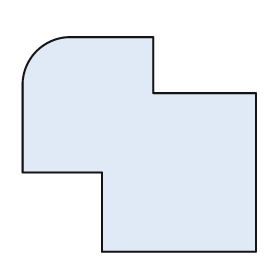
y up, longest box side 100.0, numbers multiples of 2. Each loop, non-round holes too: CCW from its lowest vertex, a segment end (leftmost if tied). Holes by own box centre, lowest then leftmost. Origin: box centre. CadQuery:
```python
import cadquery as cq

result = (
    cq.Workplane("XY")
    .moveTo(-16.0, -46.0)
    .lineTo(50.0, -46.0)
    .lineTo(50.0, 22.0)
    .lineTo(6.0, 22.0)
    .lineTo(6.0, 46.0)
    .lineTo(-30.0, 46.0)
    .threePointArc((-44.0, 40.0), (-50.0, 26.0))
    .lineTo(-50.0, -12.0)
    .lineTo(-16.0, -12.0)
    .close()
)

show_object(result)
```